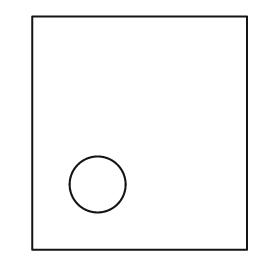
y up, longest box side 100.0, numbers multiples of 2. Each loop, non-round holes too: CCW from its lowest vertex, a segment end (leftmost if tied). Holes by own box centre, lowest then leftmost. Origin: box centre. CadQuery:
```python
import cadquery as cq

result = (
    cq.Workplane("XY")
    .moveTo(-46.0, -50.0)
    .lineTo(46.0, -50.0)
    .lineTo(46.0, 50.0)
    .lineTo(-46.0, 50.0)
    .close()
    .moveTo(-18.0, -22.0)
    .circle(12.0)
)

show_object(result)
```